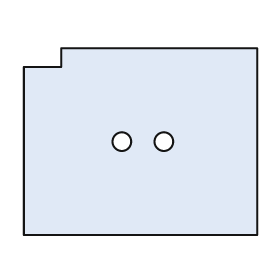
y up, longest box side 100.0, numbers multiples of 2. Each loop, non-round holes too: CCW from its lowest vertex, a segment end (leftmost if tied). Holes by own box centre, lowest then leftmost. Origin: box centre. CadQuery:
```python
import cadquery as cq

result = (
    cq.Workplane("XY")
    .moveTo(-50.0, -40.0)
    .lineTo(50.0, -40.0)
    .lineTo(50.0, 40.0)
    .lineTo(-34.0, 40.0)
    .lineTo(-34.0, 32.0)
    .lineTo(-50.0, 32.0)
    .close()
    .moveTo(-8.0, 0.0)
    .circle(4.0)
    .moveTo(10.0, 0.0)
    .circle(4.0)
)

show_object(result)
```